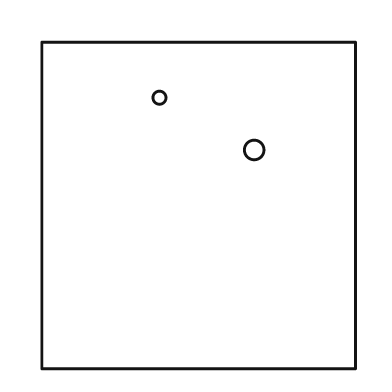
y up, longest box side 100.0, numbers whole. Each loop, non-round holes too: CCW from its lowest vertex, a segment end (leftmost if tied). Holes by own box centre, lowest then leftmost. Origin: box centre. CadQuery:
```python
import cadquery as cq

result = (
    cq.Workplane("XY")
    .moveTo(-48.0, -50.0)
    .lineTo(48.0, -50.0)
    .lineTo(48.0, 50.0)
    .lineTo(-48.0, 50.0)
    .close()
    .moveTo(17.0, 17.0)
    .circle(3.0)
    .moveTo(-12.0, 33.0)
    .circle(2.0)
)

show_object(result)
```